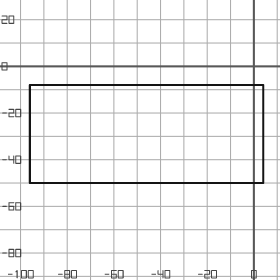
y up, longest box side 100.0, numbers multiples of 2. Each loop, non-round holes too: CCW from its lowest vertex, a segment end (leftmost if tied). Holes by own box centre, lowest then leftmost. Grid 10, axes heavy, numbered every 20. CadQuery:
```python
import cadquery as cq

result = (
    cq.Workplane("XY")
    .moveTo(-96.0, -50.0)
    .lineTo(4.0, -50.0)
    .lineTo(4.0, -8.0)
    .lineTo(-96.0, -8.0)
    .close()
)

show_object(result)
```